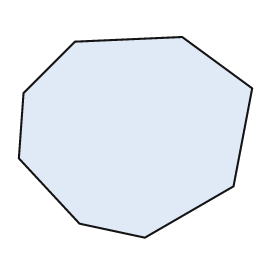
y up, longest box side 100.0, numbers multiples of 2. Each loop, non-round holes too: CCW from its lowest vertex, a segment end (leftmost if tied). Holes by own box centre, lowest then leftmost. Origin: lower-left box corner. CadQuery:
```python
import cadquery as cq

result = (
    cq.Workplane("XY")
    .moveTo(54.0, 0.0)
    .lineTo(92.0, 22.0)
    .lineTo(100.0, 64.0)
    .lineTo(70.0, 86.0)
    .lineTo(24.0, 84.0)
    .lineTo(2.0, 62.0)
    .lineTo(0.0, 34.0)
    .lineTo(26.0, 6.0)
    .close()
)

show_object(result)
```